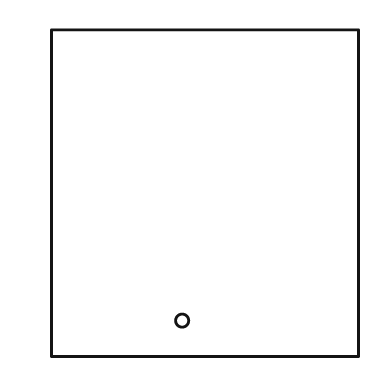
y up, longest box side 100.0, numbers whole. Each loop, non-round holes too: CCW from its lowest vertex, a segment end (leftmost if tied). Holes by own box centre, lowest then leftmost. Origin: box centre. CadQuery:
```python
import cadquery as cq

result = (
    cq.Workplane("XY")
    .moveTo(-47.0, -50.0)
    .lineTo(47.0, -50.0)
    .lineTo(47.0, 50.0)
    .lineTo(-47.0, 50.0)
    .close()
    .moveTo(-7.0, -39.0)
    .circle(2.0)
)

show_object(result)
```